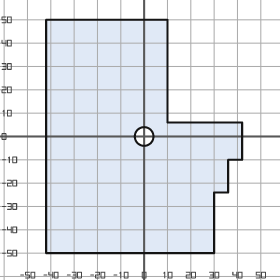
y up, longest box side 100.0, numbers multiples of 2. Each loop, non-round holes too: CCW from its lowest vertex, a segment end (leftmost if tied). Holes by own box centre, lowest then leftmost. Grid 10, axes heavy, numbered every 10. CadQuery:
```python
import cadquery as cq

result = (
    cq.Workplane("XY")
    .moveTo(-42.0, -50.0)
    .lineTo(30.0, -50.0)
    .lineTo(30.0, -24.0)
    .lineTo(36.0, -24.0)
    .lineTo(36.0, -10.0)
    .lineTo(42.0, -10.0)
    .lineTo(42.0, 6.0)
    .lineTo(10.0, 6.0)
    .lineTo(10.0, 50.0)
    .lineTo(-42.0, 50.0)
    .close()
    .moveTo(0.0, 0.0)
    .circle(4.0)
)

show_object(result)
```